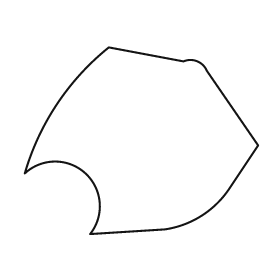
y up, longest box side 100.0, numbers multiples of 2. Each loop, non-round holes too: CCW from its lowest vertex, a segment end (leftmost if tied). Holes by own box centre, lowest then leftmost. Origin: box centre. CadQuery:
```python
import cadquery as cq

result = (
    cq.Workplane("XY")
    .moveTo(-22.0, -40.0)
    .lineTo(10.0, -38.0)
    .threePointArc((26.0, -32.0), (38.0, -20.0))
    .lineTo(50.0, -2.0)
    .lineTo(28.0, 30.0)
    .threePointArc((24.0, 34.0), (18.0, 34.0))
    .lineTo(-14.0, 40.0)
    .threePointArc((-36.0, 16.0), (-50.0, -14.0))
    .threePointArc((-24.0, -14.0), (-22.0, -40.0))
    .close()
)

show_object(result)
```